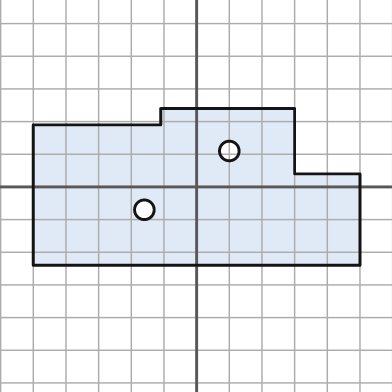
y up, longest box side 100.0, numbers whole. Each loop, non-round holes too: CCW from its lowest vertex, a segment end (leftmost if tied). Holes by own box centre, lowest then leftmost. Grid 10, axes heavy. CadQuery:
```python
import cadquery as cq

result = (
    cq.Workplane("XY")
    .moveTo(-50.0, -24.0)
    .lineTo(50.0, -24.0)
    .lineTo(50.0, 4.0)
    .lineTo(30.0, 4.0)
    .lineTo(30.0, 24.0)
    .lineTo(-11.0, 24.0)
    .lineTo(-11.0, 19.0)
    .lineTo(-50.0, 19.0)
    .close()
    .moveTo(-16.0, -7.0)
    .circle(3.0)
    .moveTo(10.0, 11.0)
    .circle(3.0)
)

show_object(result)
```